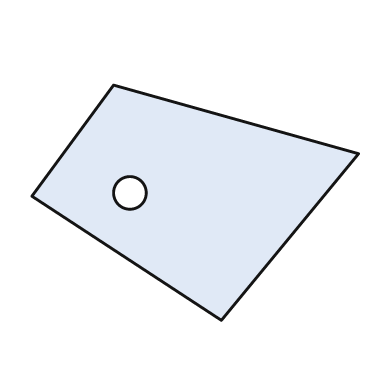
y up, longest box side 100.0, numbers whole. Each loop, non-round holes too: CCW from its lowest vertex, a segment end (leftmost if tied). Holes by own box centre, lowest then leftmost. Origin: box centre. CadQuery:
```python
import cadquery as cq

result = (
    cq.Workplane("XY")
    .moveTo(8.0, -36.0)
    .lineTo(50.0, 15.0)
    .lineTo(-25.0, 36.0)
    .lineTo(-50.0, 2.0)
    .close()
    .moveTo(-20.0, 3.0)
    .circle(5.0)
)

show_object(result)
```